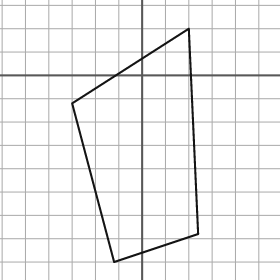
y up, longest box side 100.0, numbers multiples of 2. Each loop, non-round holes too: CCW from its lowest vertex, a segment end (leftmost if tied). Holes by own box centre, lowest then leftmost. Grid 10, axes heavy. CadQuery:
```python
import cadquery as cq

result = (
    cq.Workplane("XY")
    .moveTo(-12.0, -80.0)
    .lineTo(24.0, -68.0)
    .lineTo(20.0, 20.0)
    .lineTo(-30.0, -12.0)
    .close()
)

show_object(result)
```